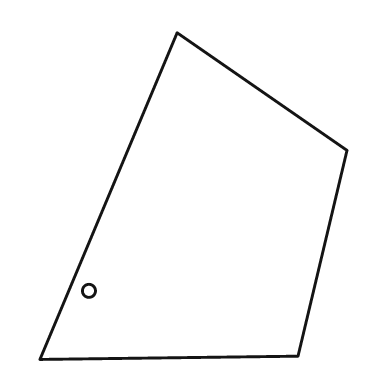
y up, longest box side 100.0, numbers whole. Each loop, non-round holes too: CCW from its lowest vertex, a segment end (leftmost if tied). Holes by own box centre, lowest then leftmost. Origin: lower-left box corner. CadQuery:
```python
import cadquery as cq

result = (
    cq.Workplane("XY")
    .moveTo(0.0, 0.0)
    .lineTo(79.0, 1.0)
    .lineTo(94.0, 64.0)
    .lineTo(42.0, 100.0)
    .close()
    .moveTo(15.0, 21.0)
    .circle(2.0)
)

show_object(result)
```